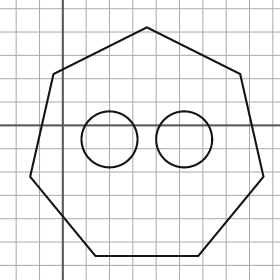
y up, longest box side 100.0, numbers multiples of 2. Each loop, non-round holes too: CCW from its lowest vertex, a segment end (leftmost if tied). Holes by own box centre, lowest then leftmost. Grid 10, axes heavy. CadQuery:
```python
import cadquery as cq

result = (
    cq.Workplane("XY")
    .moveTo(14.0, -56.0)
    .lineTo(58.0, -56.0)
    .lineTo(86.0, -22.0)
    .lineTo(76.0, 22.0)
    .lineTo(36.0, 42.0)
    .lineTo(-4.0, 22.0)
    .lineTo(-14.0, -22.0)
    .close()
    .moveTo(20.0, -6.0)
    .circle(12.0)
    .moveTo(52.0, -6.0)
    .circle(12.0)
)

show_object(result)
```